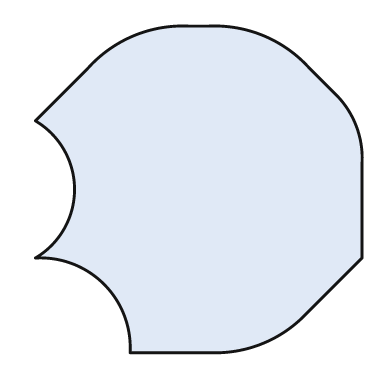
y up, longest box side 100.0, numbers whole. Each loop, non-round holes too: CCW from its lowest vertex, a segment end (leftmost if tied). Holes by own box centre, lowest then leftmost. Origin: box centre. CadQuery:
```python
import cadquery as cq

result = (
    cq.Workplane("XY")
    .moveTo(-21.0, -50.0)
    .lineTo(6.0, -50.0)
    .threePointArc((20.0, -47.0), (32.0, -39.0))
    .lineTo(50.0, -21.0)
    .lineTo(50.0, 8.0)
    .threePointArc((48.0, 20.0), (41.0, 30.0))
    .lineTo(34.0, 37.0)
    .threePointArc((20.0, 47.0), (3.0, 50.0))
    .lineTo(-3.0, 50.0)
    .threePointArc((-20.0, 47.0), (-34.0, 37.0))
    .lineTo(-50.0, 21.0)
    .threePointArc((-38.0, 0.0), (-50.0, -21.0))
    .threePointArc((-29.0, -29.0), (-21.0, -50.0))
    .close()
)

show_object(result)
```